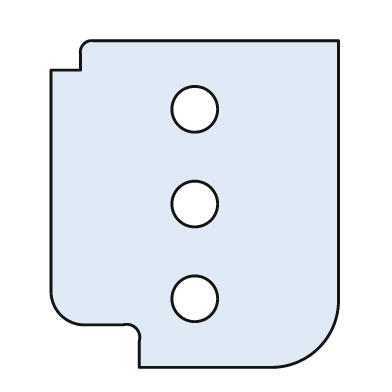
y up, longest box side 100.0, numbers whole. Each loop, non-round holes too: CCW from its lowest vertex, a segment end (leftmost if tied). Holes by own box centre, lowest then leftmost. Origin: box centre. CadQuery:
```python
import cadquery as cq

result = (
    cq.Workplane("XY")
    .moveTo(-17.0, -50.0)
    .lineTo(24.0, -50.0)
    .threePointArc((38.0, -44.0), (44.0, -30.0))
    .lineTo(44.0, 50.0)
    .lineTo(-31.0, 50.0)
    .threePointArc((-34.0, 49.0), (-35.0, 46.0))
    .lineTo(-35.0, 41.0)
    .lineTo(-44.0, 41.0)
    .lineTo(-44.0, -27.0)
    .threePointArc((-41.0, -34.0), (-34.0, -37.0))
    .lineTo(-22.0, -37.0)
    .threePointArc((-18.0, -38.0), (-17.0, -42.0))
    .close()
    .moveTo(0.0, -29.0)
    .circle(7.0)
    .moveTo(0.0, 0.0)
    .circle(7.0)
    .moveTo(0.0, 29.0)
    .circle(7.0)
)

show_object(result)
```